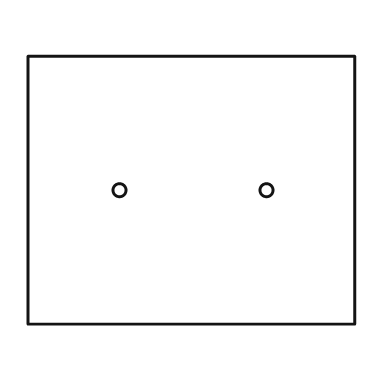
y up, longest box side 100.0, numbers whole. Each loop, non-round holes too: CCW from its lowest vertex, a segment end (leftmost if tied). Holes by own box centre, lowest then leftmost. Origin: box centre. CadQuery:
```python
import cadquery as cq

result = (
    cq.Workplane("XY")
    .moveTo(-50.0, -41.0)
    .lineTo(50.0, -41.0)
    .lineTo(50.0, 41.0)
    .lineTo(-50.0, 41.0)
    .close()
    .moveTo(-22.0, 0.0)
    .circle(2.0)
    .moveTo(23.0, 0.0)
    .circle(2.0)
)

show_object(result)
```